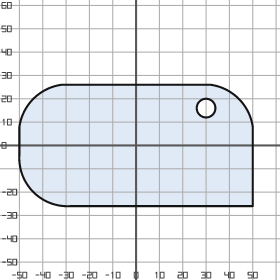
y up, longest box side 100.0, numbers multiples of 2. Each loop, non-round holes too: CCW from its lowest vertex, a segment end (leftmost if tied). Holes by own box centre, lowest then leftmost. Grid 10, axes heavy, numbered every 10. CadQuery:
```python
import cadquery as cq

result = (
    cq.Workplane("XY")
    .moveTo(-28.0, -26.0)
    .lineTo(50.0, -26.0)
    .lineTo(50.0, 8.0)
    .threePointArc((44.0, 20.0), (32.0, 26.0))
    .lineTo(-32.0, 26.0)
    .threePointArc((-44.0, 20.0), (-50.0, 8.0))
    .lineTo(-50.0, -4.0)
    .threePointArc((-44.0, -20.0), (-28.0, -26.0))
    .close()
    .moveTo(30.0, 16.0)
    .circle(4.0)
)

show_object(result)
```